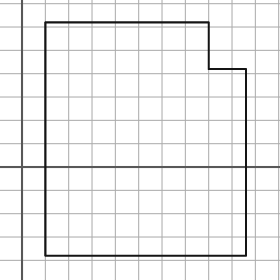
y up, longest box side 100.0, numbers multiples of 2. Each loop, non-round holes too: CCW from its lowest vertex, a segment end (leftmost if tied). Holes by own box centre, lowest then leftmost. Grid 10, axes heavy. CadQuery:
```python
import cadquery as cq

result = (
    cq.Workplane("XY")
    .moveTo(10.0, -38.0)
    .lineTo(96.0, -38.0)
    .lineTo(96.0, 42.0)
    .lineTo(80.0, 42.0)
    .lineTo(80.0, 62.0)
    .lineTo(10.0, 62.0)
    .close()
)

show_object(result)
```